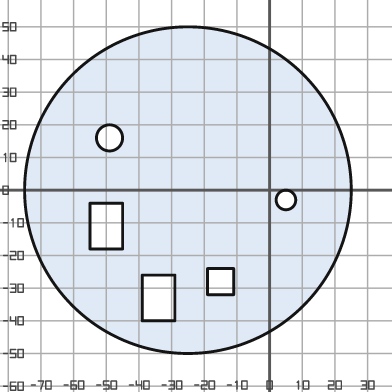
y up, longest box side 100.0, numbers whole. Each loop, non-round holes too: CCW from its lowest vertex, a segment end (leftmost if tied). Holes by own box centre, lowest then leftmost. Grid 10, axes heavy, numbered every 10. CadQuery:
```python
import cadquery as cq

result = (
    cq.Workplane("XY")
    .moveTo(-25.0, 0.0)
    .circle(50.0)
    .moveTo(-39.0, -40.0)
    .lineTo(-29.0, -40.0)
    .lineTo(-29.0, -26.0)
    .lineTo(-39.0, -26.0)
    .close()
    .moveTo(-19.0, -32.0)
    .lineTo(-11.0, -32.0)
    .lineTo(-11.0, -24.0)
    .lineTo(-19.0, -24.0)
    .close()
    .moveTo(-55.0, -18.0)
    .lineTo(-45.0, -18.0)
    .lineTo(-45.0, -4.0)
    .lineTo(-55.0, -4.0)
    .close()
    .moveTo(5.0, -3.0)
    .circle(3.0)
    .moveTo(-49.0, 16.0)
    .circle(4.0)
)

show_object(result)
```